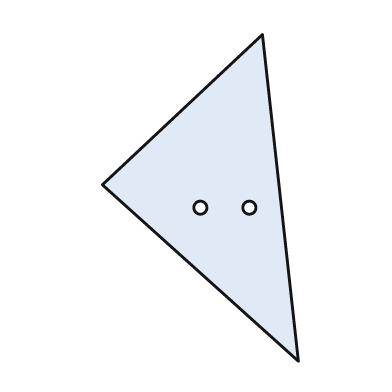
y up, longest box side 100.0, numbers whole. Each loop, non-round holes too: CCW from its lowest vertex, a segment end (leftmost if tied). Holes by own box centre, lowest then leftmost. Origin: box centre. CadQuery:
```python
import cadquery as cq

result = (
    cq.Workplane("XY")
    .moveTo(30.0, -50.0)
    .lineTo(19.0, 50.0)
    .lineTo(-30.0, 4.0)
    .close()
    .moveTo(0.0, -3.0)
    .circle(2.0)
    .moveTo(15.0, -3.0)
    .circle(2.0)
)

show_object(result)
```